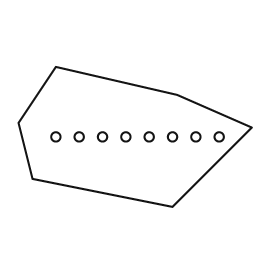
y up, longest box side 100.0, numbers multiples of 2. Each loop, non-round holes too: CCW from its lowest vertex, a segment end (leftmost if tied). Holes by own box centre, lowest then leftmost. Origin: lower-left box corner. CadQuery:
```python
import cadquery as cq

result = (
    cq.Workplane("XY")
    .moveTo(66.0, 0.0)
    .lineTo(100.0, 34.0)
    .lineTo(68.0, 48.0)
    .lineTo(16.0, 60.0)
    .lineTo(0.0, 36.0)
    .lineTo(6.0, 12.0)
    .close()
    .moveTo(16.0, 30.0)
    .circle(2.0)
    .moveTo(26.0, 30.0)
    .circle(2.0)
    .moveTo(36.0, 30.0)
    .circle(2.0)
    .moveTo(46.0, 30.0)
    .circle(2.0)
    .moveTo(56.0, 30.0)
    .circle(2.0)
    .moveTo(66.0, 30.0)
    .circle(2.0)
    .moveTo(76.0, 30.0)
    .circle(2.0)
    .moveTo(86.0, 30.0)
    .circle(2.0)
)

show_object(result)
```